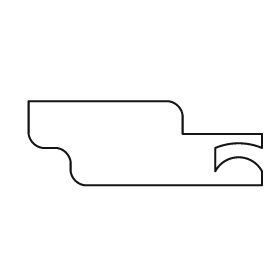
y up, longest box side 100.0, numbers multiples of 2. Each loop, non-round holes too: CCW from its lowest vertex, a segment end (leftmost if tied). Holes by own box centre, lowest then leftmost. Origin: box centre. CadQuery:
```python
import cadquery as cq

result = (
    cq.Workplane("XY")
    .moveTo(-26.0, -18.0)
    .lineTo(50.0, -18.0)
    .lineTo(50.0, -12.0)
    .threePointArc((40.0, -6.0), (30.0, -12.0))
    .lineTo(30.0, -2.0)
    .threePointArc((40.0, 0.0), (50.0, -2.0))
    .lineTo(50.0, 4.0)
    .lineTo(16.0, 4.0)
    .lineTo(16.0, 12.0)
    .threePointArc((14.0, 16.0), (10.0, 18.0))
    .lineTo(-50.0, 18.0)
    .lineTo(-50.0, 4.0)
    .threePointArc((-48.0, 0.0), (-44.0, -2.0))
    .lineTo(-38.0, -2.0)
    .threePointArc((-34.0, -4.0), (-32.0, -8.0))
    .lineTo(-32.0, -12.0)
    .threePointArc((-30.0, -16.0), (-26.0, -18.0))
    .close()
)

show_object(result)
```